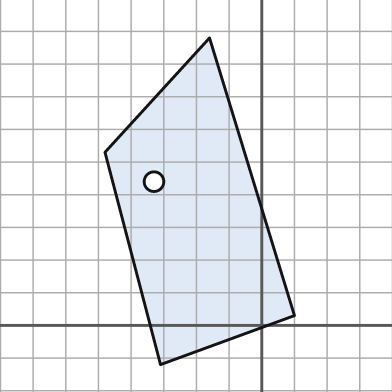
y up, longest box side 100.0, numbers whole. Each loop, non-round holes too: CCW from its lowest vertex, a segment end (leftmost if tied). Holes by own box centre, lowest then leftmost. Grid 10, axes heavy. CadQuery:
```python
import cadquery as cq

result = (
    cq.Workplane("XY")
    .moveTo(-31.0, -12.0)
    .lineTo(10.0, 3.0)
    .lineTo(-16.0, 88.0)
    .lineTo(-48.0, 53.0)
    .close()
    .moveTo(-33.0, 44.0)
    .circle(3.0)
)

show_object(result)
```